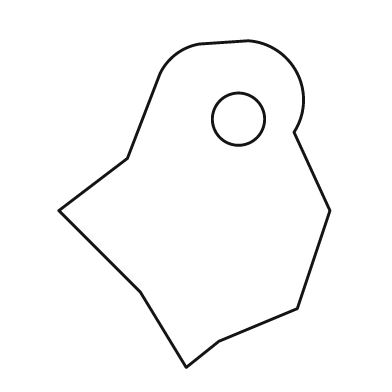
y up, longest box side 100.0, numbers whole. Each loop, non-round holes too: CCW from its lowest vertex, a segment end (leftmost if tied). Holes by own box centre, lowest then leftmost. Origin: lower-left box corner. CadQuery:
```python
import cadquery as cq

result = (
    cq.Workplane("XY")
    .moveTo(39.0, 0.0)
    .lineTo(49.0, 8.0)
    .lineTo(73.0, 18.0)
    .lineTo(83.0, 48.0)
    .lineTo(72.0, 72.0)
    .threePointArc((73.0, 90.0), (58.0, 100.0))
    .lineTo(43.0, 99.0)
    .threePointArc((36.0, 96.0), (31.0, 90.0))
    .lineTo(21.0, 64.0)
    .lineTo(0.0, 48.0)
    .lineTo(25.0, 23.0)
    .close()
    .moveTo(55.0, 76.0)
    .circle(8.0)
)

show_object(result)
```